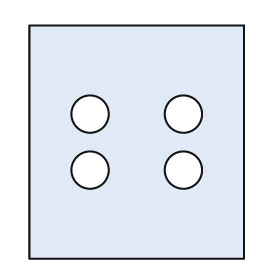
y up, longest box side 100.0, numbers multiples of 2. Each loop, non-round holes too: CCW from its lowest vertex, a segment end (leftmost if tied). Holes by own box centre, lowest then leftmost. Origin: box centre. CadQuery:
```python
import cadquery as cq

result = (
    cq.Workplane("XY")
    .moveTo(-46.0, -50.0)
    .lineTo(46.0, -50.0)
    .lineTo(46.0, 50.0)
    .lineTo(-46.0, 50.0)
    .close()
    .moveTo(-20.0, -12.0)
    .circle(8.0)
    .moveTo(20.0, -12.0)
    .circle(8.0)
    .moveTo(-20.0, 12.0)
    .circle(8.0)
    .moveTo(20.0, 12.0)
    .circle(8.0)
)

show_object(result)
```